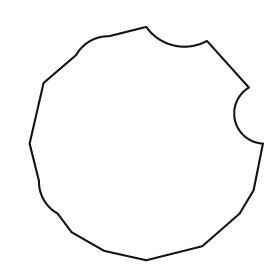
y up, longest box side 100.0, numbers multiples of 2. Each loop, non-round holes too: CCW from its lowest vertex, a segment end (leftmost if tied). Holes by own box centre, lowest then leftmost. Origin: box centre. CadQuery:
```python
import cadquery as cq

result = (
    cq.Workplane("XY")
    .moveTo(0.0, -50.0)
    .lineTo(24.0, -44.0)
    .lineTo(40.0, -30.0)
    .lineTo(46.0, -20.0)
    .lineTo(50.0, 0.0)
    .threePointArc((38.0, 10.0), (44.0, 24.0))
    .lineTo(26.0, 44.0)
    .threePointArc((12.0, 42.0), (0.0, 50.0))
    .lineTo(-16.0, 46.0)
    .threePointArc((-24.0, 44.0), (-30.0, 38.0))
    .lineTo(-44.0, 26.0)
    .lineTo(-50.0, 0.0)
    .lineTo(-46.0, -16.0)
    .threePointArc((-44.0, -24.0), (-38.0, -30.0))
    .lineTo(-32.0, -38.0)
    .lineTo(-18.0, -46.0)
    .close()
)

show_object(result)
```